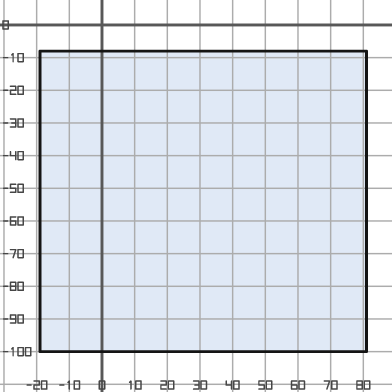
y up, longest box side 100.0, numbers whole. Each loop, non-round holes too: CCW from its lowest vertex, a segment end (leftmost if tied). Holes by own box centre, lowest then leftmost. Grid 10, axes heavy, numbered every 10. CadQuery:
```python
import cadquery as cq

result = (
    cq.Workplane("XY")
    .moveTo(-19.0, -100.0)
    .lineTo(81.0, -100.0)
    .lineTo(81.0, -8.0)
    .lineTo(-19.0, -8.0)
    .close()
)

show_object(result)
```